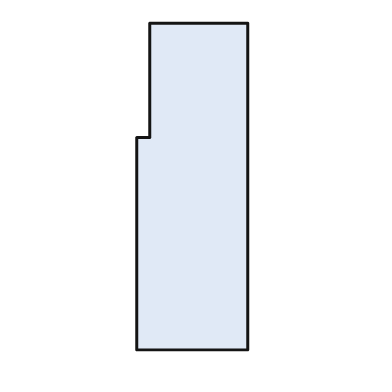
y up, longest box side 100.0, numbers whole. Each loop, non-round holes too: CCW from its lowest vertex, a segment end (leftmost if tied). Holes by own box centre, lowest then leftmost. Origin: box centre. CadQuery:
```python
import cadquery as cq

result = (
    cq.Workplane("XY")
    .moveTo(-17.0, -50.0)
    .lineTo(17.0, -50.0)
    .lineTo(17.0, 50.0)
    .lineTo(-13.0, 50.0)
    .lineTo(-13.0, 15.0)
    .lineTo(-17.0, 15.0)
    .close()
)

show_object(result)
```